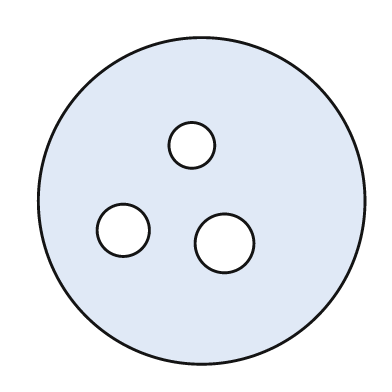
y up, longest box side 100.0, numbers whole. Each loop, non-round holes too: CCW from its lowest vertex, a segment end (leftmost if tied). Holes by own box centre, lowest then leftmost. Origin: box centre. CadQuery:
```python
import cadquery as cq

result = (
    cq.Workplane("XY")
    .moveTo(0.0, 0.0)
    .circle(50.0)
    .moveTo(7.0, -13.0)
    .circle(9.0)
    .moveTo(-24.0, -9.0)
    .circle(8.0)
    .moveTo(-3.0, 17.0)
    .circle(7.0)
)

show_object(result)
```